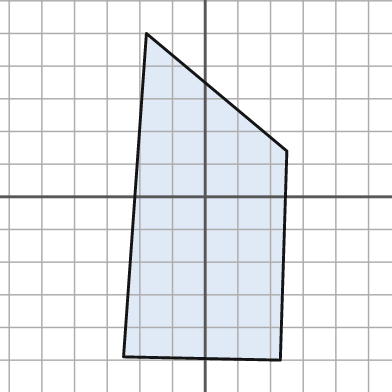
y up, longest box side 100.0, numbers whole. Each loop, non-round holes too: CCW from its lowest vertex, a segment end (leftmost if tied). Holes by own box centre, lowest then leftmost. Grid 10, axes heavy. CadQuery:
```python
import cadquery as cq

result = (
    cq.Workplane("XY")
    .moveTo(23.0, -50.0)
    .lineTo(25.0, 14.0)
    .lineTo(-18.0, 50.0)
    .lineTo(-25.0, -49.0)
    .close()
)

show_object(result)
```